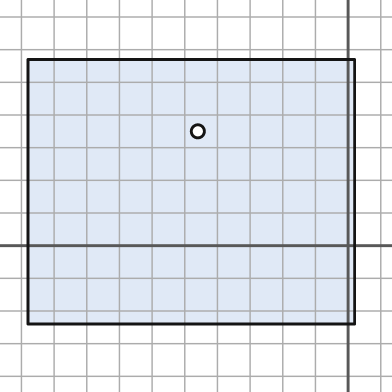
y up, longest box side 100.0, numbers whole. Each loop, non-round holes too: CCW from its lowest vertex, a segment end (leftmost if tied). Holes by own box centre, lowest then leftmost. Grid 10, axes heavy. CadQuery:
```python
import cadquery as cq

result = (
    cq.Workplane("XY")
    .moveTo(-98.0, -24.0)
    .lineTo(2.0, -24.0)
    .lineTo(2.0, 57.0)
    .lineTo(-98.0, 57.0)
    .close()
    .moveTo(-46.0, 35.0)
    .circle(2.0)
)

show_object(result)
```